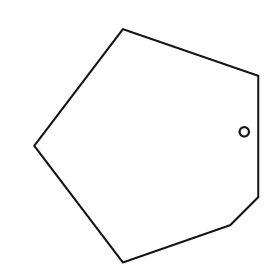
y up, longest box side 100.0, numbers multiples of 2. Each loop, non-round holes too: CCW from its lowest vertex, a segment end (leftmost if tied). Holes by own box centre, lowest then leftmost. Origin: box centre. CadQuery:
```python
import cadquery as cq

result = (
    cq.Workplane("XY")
    .moveTo(-10.0, -50.0)
    .lineTo(36.0, -34.0)
    .lineTo(48.0, -22.0)
    .lineTo(48.0, 30.0)
    .lineTo(-10.0, 50.0)
    .lineTo(-48.0, 0.0)
    .close()
    .moveTo(42.0, 6.0)
    .circle(2.0)
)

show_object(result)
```